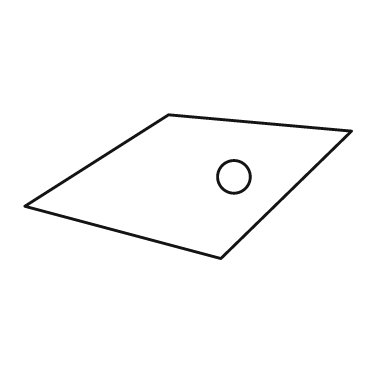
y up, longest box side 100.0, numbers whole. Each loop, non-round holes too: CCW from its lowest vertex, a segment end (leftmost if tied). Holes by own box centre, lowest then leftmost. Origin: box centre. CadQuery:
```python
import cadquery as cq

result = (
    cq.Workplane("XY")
    .moveTo(10.0, -22.0)
    .lineTo(50.0, 17.0)
    .lineTo(-6.0, 22.0)
    .lineTo(-50.0, -6.0)
    .close()
    .moveTo(14.0, 3.0)
    .circle(5.0)
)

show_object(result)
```